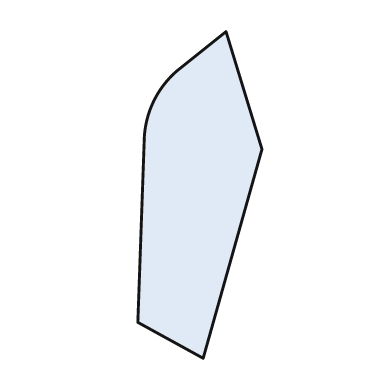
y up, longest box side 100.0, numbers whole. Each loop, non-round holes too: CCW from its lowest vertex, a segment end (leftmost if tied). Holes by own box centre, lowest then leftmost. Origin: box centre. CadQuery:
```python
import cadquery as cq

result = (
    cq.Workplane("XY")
    .moveTo(1.0, -50.0)
    .lineTo(19.0, 14.0)
    .lineTo(8.0, 50.0)
    .lineTo(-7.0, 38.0)
    .threePointArc((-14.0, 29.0), (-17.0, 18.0))
    .lineTo(-19.0, -39.0)
    .close()
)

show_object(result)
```